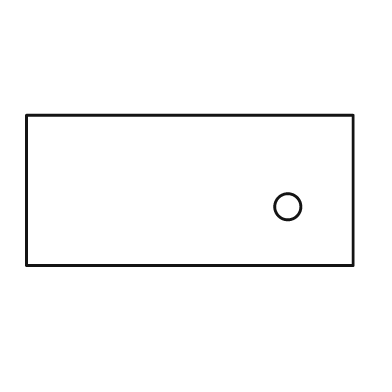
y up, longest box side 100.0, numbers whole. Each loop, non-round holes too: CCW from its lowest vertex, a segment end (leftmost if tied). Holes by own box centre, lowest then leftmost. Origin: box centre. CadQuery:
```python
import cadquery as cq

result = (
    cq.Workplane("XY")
    .moveTo(-50.0, -23.0)
    .lineTo(50.0, -23.0)
    .lineTo(50.0, 23.0)
    .lineTo(-50.0, 23.0)
    .close()
    .moveTo(30.0, -5.0)
    .circle(4.0)
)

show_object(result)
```